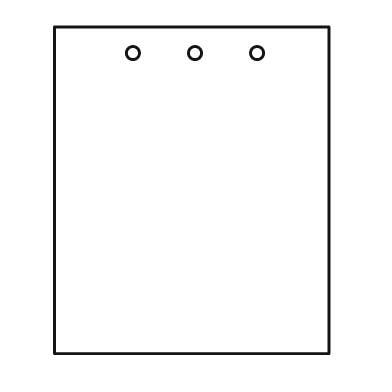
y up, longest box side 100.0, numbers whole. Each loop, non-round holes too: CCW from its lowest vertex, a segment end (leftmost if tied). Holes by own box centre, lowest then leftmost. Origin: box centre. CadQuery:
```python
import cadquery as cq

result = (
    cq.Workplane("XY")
    .moveTo(-42.0, -50.0)
    .lineTo(42.0, -50.0)
    .lineTo(42.0, 50.0)
    .lineTo(-42.0, 50.0)
    .close()
    .moveTo(-18.0, 42.0)
    .circle(2.0)
    .moveTo(1.0, 42.0)
    .circle(2.0)
    .moveTo(20.0, 42.0)
    .circle(2.0)
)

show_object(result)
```